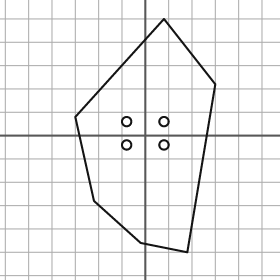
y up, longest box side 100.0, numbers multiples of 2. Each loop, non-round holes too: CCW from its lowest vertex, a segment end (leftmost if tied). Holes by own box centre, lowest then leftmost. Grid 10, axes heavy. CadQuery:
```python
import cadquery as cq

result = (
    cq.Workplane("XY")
    .moveTo(18.0, -50.0)
    .lineTo(30.0, 22.0)
    .lineTo(8.0, 50.0)
    .lineTo(-30.0, 8.0)
    .lineTo(-22.0, -28.0)
    .lineTo(-2.0, -46.0)
    .close()
    .moveTo(-8.0, -4.0)
    .circle(2.0)
    .moveTo(8.0, -4.0)
    .circle(2.0)
    .moveTo(-8.0, 6.0)
    .circle(2.0)
    .moveTo(8.0, 6.0)
    .circle(2.0)
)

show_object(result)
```